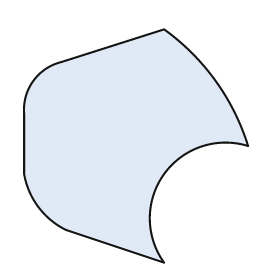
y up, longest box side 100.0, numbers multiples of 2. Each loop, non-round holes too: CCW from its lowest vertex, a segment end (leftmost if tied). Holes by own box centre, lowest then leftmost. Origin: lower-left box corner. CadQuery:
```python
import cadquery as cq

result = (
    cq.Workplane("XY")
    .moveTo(60.0, 0.0)
    .threePointArc((60.0, 38.0), (96.0, 50.0))
    .threePointArc((82.0, 78.0), (60.0, 100.0))
    .lineTo(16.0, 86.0)
    .threePointArc((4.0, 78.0), (0.0, 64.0))
    .lineTo(0.0, 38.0)
    .threePointArc((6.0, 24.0), (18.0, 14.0))
    .close()
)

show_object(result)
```